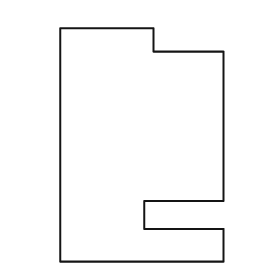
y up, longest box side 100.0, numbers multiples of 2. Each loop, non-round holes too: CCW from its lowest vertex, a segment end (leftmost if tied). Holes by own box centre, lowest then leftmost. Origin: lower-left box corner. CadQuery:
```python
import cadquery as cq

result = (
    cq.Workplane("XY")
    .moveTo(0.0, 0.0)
    .lineTo(70.0, 0.0)
    .lineTo(70.0, 14.0)
    .lineTo(36.0, 14.0)
    .lineTo(36.0, 26.0)
    .lineTo(70.0, 26.0)
    .lineTo(70.0, 90.0)
    .lineTo(40.0, 90.0)
    .lineTo(40.0, 100.0)
    .lineTo(0.0, 100.0)
    .close()
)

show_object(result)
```